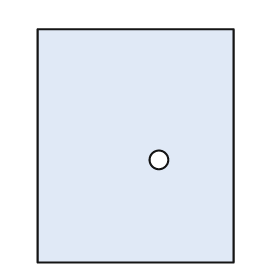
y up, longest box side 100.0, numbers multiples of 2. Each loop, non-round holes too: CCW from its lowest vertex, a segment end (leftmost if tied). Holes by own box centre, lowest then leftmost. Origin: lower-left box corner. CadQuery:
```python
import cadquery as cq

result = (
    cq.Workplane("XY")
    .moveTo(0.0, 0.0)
    .lineTo(84.0, 0.0)
    .lineTo(84.0, 100.0)
    .lineTo(0.0, 100.0)
    .close()
    .moveTo(52.0, 44.0)
    .circle(4.0)
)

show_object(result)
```